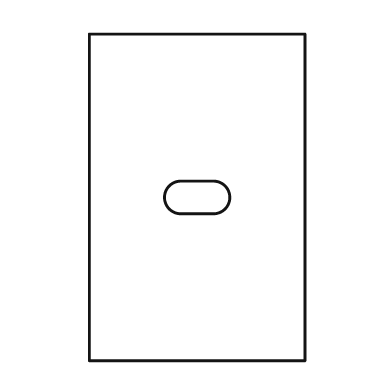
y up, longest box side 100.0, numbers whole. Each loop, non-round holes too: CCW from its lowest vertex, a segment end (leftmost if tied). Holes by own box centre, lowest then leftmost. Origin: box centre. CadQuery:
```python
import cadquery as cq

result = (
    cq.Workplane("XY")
    .moveTo(-33.0, -50.0)
    .lineTo(33.0, -50.0)
    .lineTo(33.0, 50.0)
    .lineTo(-33.0, 50.0)
    .close()
    .moveTo(-5.0, -5.0)
    .lineTo(5.0, -5.0)
    .threePointArc((10.0, 0.0), (5.0, 5.0))
    .lineTo(-5.0, 5.0)
    .threePointArc((-10.0, 0.0), (-5.0, -5.0))
    .close()
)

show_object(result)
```